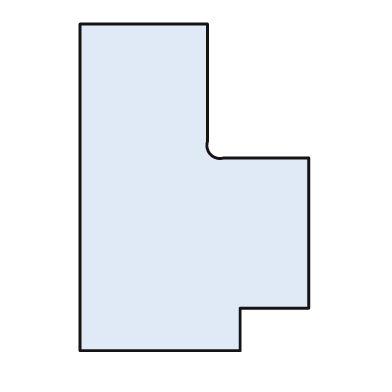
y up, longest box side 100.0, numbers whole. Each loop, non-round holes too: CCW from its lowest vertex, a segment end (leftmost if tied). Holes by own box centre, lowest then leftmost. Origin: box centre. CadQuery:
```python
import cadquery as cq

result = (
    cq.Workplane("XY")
    .moveTo(-35.0, -50.0)
    .lineTo(14.0, -50.0)
    .lineTo(14.0, -37.0)
    .lineTo(35.0, -37.0)
    .lineTo(35.0, 9.0)
    .lineTo(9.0, 9.0)
    .threePointArc((5.0, 10.0), (4.0, 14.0))
    .lineTo(4.0, 50.0)
    .lineTo(-35.0, 50.0)
    .close()
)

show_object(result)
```